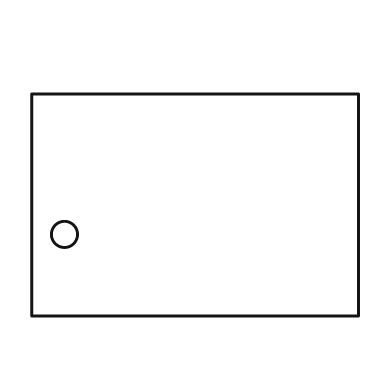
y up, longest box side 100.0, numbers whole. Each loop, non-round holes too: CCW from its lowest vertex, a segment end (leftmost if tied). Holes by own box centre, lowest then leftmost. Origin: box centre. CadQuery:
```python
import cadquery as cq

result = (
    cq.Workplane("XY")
    .moveTo(-50.0, -34.0)
    .lineTo(50.0, -34.0)
    .lineTo(50.0, 34.0)
    .lineTo(-50.0, 34.0)
    .close()
    .moveTo(-40.0, -9.0)
    .circle(4.0)
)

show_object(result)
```